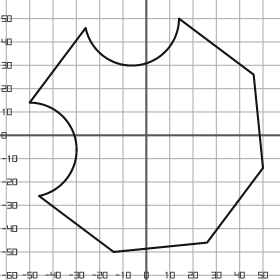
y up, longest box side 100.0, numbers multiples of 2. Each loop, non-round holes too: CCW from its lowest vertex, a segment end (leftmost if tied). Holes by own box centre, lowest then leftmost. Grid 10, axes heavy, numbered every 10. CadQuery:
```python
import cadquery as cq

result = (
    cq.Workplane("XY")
    .moveTo(-14.0, -50.0)
    .lineTo(26.0, -46.0)
    .lineTo(50.0, -14.0)
    .lineTo(46.0, 26.0)
    .lineTo(14.0, 50.0)
    .threePointArc((-4.0, 30.0), (-26.0, 46.0))
    .lineTo(-50.0, 14.0)
    .threePointArc((-30.0, -4.0), (-46.0, -26.0))
    .close()
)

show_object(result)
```